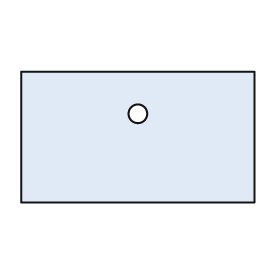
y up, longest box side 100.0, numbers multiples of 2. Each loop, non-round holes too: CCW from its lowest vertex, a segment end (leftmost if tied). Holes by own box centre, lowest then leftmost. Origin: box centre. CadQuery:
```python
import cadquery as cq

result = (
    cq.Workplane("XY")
    .moveTo(-50.0, -28.0)
    .lineTo(50.0, -28.0)
    .lineTo(50.0, 28.0)
    .lineTo(-50.0, 28.0)
    .close()
    .moveTo(0.0, 10.0)
    .circle(4.0)
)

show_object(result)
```